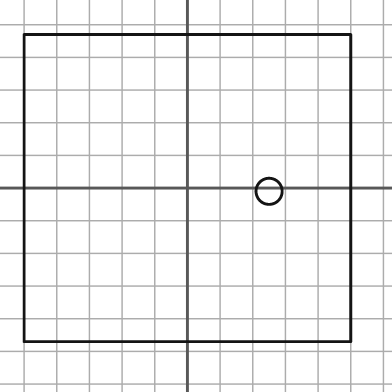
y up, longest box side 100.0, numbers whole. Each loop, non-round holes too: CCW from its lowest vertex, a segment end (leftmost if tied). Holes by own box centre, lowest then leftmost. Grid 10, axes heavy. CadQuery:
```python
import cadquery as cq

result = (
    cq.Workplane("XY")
    .moveTo(-50.0, -47.0)
    .lineTo(50.0, -47.0)
    .lineTo(50.0, 47.0)
    .lineTo(-50.0, 47.0)
    .close()
    .moveTo(25.0, -1.0)
    .circle(4.0)
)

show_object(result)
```